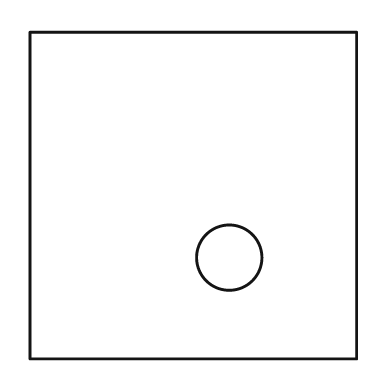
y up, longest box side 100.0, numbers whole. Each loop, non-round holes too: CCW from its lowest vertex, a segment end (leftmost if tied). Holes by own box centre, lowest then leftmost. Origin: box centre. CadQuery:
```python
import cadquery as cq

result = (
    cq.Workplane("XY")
    .moveTo(-50.0, -50.0)
    .lineTo(50.0, -50.0)
    .lineTo(50.0, 50.0)
    .lineTo(-50.0, 50.0)
    .close()
    .moveTo(11.0, -19.0)
    .circle(10.0)
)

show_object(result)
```